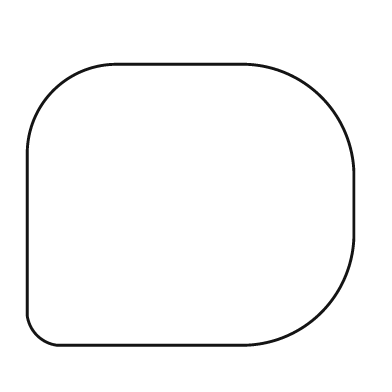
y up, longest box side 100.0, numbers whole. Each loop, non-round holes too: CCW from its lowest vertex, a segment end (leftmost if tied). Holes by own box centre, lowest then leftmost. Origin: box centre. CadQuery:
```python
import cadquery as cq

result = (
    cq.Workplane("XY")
    .moveTo(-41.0, -43.0)
    .lineTo(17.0, -43.0)
    .threePointArc((40.0, -33.0), (50.0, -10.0))
    .lineTo(50.0, 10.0)
    .threePointArc((40.0, 33.0), (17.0, 43.0))
    .lineTo(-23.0, 43.0)
    .threePointArc((-42.0, 35.0), (-50.0, 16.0))
    .lineTo(-50.0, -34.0)
    .threePointArc((-47.0, -40.0), (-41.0, -43.0))
    .close()
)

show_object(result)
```